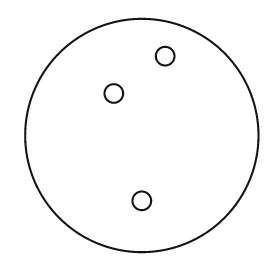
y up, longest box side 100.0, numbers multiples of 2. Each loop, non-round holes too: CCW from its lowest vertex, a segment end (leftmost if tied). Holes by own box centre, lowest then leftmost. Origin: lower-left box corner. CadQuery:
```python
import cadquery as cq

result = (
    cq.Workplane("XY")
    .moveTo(50.0, 50.0)
    .circle(50.0)
    .moveTo(50.0, 22.0)
    .circle(4.0)
    .moveTo(38.0, 68.0)
    .circle(4.0)
    .moveTo(60.0, 84.0)
    .circle(4.0)
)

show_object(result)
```